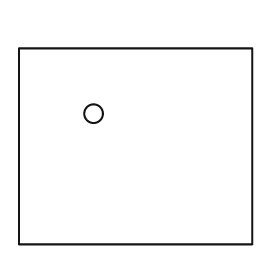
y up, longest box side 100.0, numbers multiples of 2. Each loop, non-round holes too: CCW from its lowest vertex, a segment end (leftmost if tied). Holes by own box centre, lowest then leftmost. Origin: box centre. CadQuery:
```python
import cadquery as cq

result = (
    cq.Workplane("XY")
    .moveTo(-50.0, -42.0)
    .lineTo(50.0, -42.0)
    .lineTo(50.0, 42.0)
    .lineTo(-50.0, 42.0)
    .close()
    .moveTo(-18.0, 14.0)
    .circle(4.0)
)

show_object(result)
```